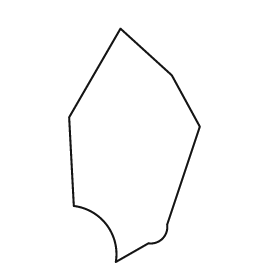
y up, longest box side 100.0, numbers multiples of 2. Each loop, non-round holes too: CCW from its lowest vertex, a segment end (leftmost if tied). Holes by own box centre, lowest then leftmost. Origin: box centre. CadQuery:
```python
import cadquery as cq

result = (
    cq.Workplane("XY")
    .moveTo(-8.0, -50.0)
    .lineTo(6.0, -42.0)
    .threePointArc((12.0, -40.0), (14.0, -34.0))
    .lineTo(28.0, 8.0)
    .lineTo(16.0, 30.0)
    .lineTo(-6.0, 50.0)
    .lineTo(-28.0, 12.0)
    .lineTo(-26.0, -26.0)
    .threePointArc((-12.0, -34.0), (-8.0, -50.0))
    .close()
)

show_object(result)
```